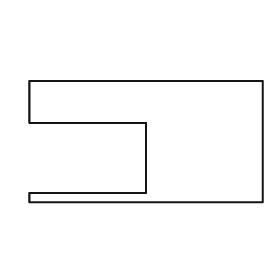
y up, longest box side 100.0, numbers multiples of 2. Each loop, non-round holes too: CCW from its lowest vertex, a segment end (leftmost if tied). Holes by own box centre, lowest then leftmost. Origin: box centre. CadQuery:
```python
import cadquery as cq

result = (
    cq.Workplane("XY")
    .moveTo(-50.0, -26.0)
    .lineTo(50.0, -26.0)
    .lineTo(50.0, 26.0)
    .lineTo(-50.0, 26.0)
    .lineTo(-50.0, 8.0)
    .lineTo(0.0, 8.0)
    .lineTo(0.0, -22.0)
    .lineTo(-50.0, -22.0)
    .close()
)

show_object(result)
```